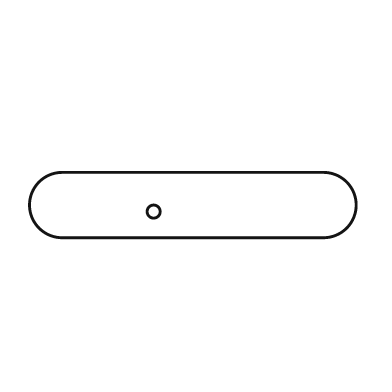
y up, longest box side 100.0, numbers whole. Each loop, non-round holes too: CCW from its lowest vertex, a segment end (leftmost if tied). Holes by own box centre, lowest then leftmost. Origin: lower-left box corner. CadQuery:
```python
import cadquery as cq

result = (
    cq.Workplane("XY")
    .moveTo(10.0, 0.0)
    .lineTo(90.0, 0.0)
    .threePointArc((100.0, 10.0), (90.0, 20.0))
    .lineTo(10.0, 20.0)
    .threePointArc((0.0, 10.0), (10.0, 0.0))
    .close()
    .moveTo(38.0, 8.0)
    .circle(2.0)
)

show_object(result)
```